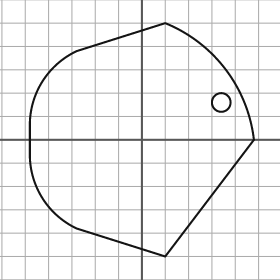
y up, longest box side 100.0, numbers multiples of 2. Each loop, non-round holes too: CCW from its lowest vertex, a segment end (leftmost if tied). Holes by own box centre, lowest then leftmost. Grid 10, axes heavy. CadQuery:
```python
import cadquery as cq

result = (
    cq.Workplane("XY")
    .moveTo(10.0, -50.0)
    .lineTo(48.0, 0.0)
    .threePointArc((36.0, 30.0), (10.0, 50.0))
    .lineTo(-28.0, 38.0)
    .threePointArc((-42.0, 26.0), (-48.0, 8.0))
    .lineTo(-48.0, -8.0)
    .threePointArc((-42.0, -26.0), (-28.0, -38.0))
    .close()
    .moveTo(34.0, 16.0)
    .circle(4.0)
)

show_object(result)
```